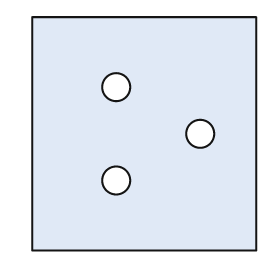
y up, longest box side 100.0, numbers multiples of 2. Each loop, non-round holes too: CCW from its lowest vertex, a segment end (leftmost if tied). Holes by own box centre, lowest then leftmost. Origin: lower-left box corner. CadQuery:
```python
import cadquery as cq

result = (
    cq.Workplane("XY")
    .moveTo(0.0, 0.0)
    .lineTo(96.0, 0.0)
    .lineTo(96.0, 100.0)
    .lineTo(0.0, 100.0)
    .close()
    .moveTo(36.0, 30.0)
    .circle(6.0)
    .moveTo(72.0, 50.0)
    .circle(6.0)
    .moveTo(36.0, 70.0)
    .circle(6.0)
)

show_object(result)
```